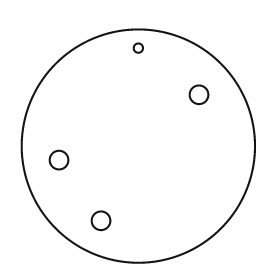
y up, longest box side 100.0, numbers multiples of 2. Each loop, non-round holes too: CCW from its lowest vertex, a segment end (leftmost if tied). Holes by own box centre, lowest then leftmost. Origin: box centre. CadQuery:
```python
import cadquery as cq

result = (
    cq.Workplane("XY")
    .moveTo(0.0, 0.0)
    .circle(50.0)
    .moveTo(-16.0, -32.0)
    .circle(4.0)
    .moveTo(-34.0, -6.0)
    .circle(4.0)
    .moveTo(26.0, 22.0)
    .circle(4.0)
    .moveTo(0.0, 42.0)
    .circle(2.0)
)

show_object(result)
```